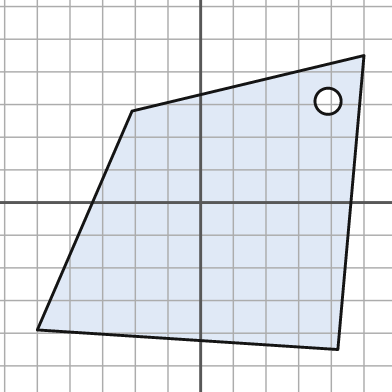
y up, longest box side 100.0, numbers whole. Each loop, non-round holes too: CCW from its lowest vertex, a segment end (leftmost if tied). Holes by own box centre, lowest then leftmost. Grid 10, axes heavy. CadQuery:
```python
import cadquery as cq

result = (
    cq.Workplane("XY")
    .moveTo(42.0, -45.0)
    .lineTo(50.0, 45.0)
    .lineTo(-21.0, 28.0)
    .lineTo(-50.0, -39.0)
    .close()
    .moveTo(39.0, 31.0)
    .circle(4.0)
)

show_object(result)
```